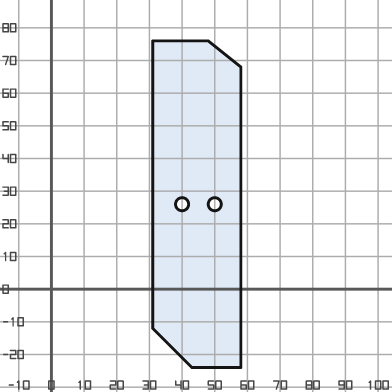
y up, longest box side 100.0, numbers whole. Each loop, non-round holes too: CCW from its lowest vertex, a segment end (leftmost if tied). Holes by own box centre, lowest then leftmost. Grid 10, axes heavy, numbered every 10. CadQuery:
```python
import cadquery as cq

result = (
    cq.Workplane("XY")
    .moveTo(43.0, -24.0)
    .lineTo(58.0, -24.0)
    .lineTo(58.0, 68.0)
    .lineTo(48.0, 76.0)
    .lineTo(31.0, 76.0)
    .lineTo(31.0, -12.0)
    .close()
    .moveTo(40.0, 26.0)
    .circle(2.0)
    .moveTo(50.0, 26.0)
    .circle(2.0)
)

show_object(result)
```